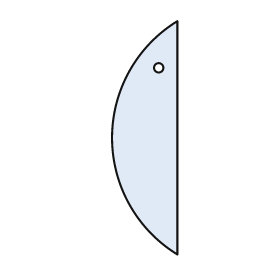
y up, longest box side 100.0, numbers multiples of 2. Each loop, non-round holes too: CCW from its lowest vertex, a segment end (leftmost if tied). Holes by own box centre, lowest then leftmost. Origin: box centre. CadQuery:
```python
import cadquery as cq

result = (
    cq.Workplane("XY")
    .moveTo(14.0, -50.0)
    .lineTo(14.0, 50.0)
    .threePointArc((-14.0, 0.0), (14.0, -50.0))
    .close()
    .moveTo(6.0, 30.0)
    .circle(2.0)
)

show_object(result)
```